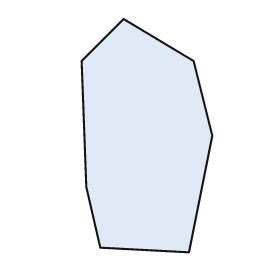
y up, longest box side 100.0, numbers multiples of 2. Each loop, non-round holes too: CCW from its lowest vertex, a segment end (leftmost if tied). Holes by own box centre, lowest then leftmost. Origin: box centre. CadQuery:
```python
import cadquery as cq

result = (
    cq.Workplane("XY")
    .moveTo(18.0, -50.0)
    .lineTo(28.0, 0.0)
    .lineTo(20.0, 32.0)
    .lineTo(-10.0, 50.0)
    .lineTo(-28.0, 32.0)
    .lineTo(-26.0, -22.0)
    .lineTo(-20.0, -48.0)
    .close()
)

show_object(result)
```